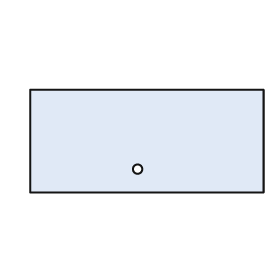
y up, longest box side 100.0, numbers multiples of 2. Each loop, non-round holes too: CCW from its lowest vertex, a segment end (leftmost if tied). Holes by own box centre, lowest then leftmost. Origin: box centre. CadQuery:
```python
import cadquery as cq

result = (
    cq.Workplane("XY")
    .moveTo(-50.0, -22.0)
    .lineTo(50.0, -22.0)
    .lineTo(50.0, 22.0)
    .lineTo(-50.0, 22.0)
    .close()
    .moveTo(-4.0, -12.0)
    .circle(2.0)
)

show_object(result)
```